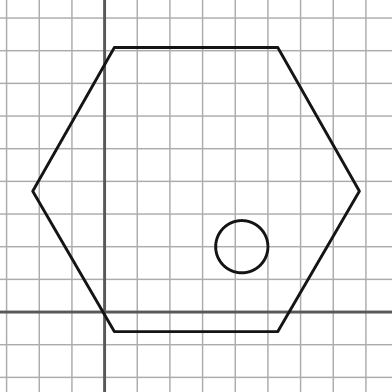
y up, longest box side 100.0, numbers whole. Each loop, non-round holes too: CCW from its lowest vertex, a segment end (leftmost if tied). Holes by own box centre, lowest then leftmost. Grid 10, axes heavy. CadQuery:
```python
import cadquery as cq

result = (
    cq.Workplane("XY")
    .moveTo(3.0, -6.0)
    .lineTo(53.0, -6.0)
    .lineTo(78.0, 37.0)
    .lineTo(53.0, 81.0)
    .lineTo(3.0, 81.0)
    .lineTo(-22.0, 37.0)
    .close()
    .moveTo(42.0, 20.0)
    .circle(8.0)
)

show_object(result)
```